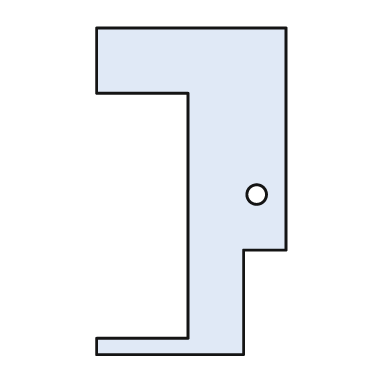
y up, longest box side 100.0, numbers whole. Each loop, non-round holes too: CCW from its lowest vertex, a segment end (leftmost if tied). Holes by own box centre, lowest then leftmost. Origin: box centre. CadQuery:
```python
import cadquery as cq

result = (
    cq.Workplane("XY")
    .moveTo(-29.0, -50.0)
    .lineTo(16.0, -50.0)
    .lineTo(16.0, -18.0)
    .lineTo(29.0, -18.0)
    .lineTo(29.0, 50.0)
    .lineTo(-29.0, 50.0)
    .lineTo(-29.0, 30.0)
    .lineTo(-1.0, 30.0)
    .lineTo(-1.0, -45.0)
    .lineTo(-29.0, -45.0)
    .close()
    .moveTo(20.0, -1.0)
    .circle(3.0)
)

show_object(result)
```